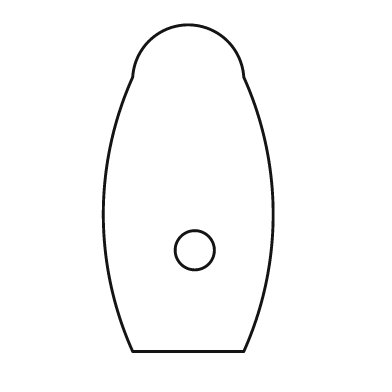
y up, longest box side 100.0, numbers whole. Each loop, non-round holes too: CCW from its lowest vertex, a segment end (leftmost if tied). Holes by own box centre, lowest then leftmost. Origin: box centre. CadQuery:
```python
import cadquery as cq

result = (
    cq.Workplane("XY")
    .moveTo(-17.0, -50.0)
    .lineTo(17.0, -50.0)
    .threePointArc((26.0, -8.0), (17.0, 34.0))
    .threePointArc((0.0, 50.0), (-17.0, 34.0))
    .threePointArc((-26.0, -8.0), (-17.0, -50.0))
    .close()
    .moveTo(2.0, -19.0)
    .circle(6.0)
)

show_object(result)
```